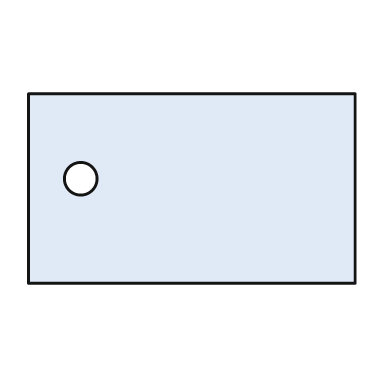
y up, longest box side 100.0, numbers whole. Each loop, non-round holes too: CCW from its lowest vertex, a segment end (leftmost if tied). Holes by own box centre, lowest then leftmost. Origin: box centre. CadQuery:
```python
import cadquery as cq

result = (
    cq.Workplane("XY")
    .moveTo(-50.0, -29.0)
    .lineTo(50.0, -29.0)
    .lineTo(50.0, 29.0)
    .lineTo(-50.0, 29.0)
    .close()
    .moveTo(-34.0, 3.0)
    .circle(5.0)
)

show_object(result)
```